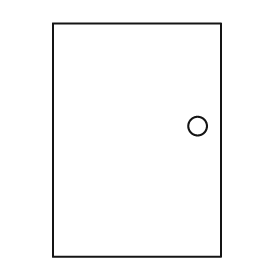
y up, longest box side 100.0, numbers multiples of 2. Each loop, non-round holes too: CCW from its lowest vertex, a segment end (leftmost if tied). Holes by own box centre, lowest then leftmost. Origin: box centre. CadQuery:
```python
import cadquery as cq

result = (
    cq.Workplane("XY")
    .moveTo(-36.0, -50.0)
    .lineTo(36.0, -50.0)
    .lineTo(36.0, 50.0)
    .lineTo(-36.0, 50.0)
    .close()
    .moveTo(26.0, 6.0)
    .circle(4.0)
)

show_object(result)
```